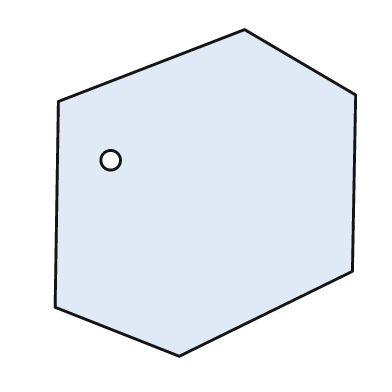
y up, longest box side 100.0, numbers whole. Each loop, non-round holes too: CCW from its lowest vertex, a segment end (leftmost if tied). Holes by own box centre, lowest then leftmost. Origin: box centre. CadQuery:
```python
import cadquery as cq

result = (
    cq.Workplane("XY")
    .moveTo(-8.0, -50.0)
    .lineTo(45.0, -24.0)
    .lineTo(46.0, 30.0)
    .lineTo(12.0, 50.0)
    .lineTo(-45.0, 28.0)
    .lineTo(-46.0, -35.0)
    .close()
    .moveTo(-29.0, 10.0)
    .circle(3.0)
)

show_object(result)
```